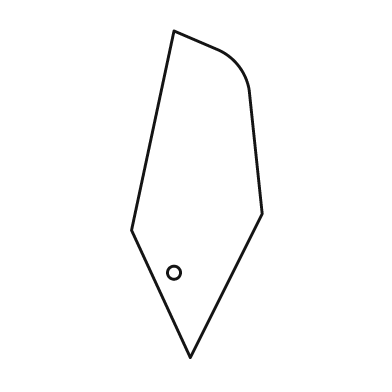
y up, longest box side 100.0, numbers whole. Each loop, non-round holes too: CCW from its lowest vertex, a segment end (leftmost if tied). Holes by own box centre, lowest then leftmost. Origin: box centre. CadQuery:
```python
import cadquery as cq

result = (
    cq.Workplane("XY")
    .moveTo(-2.0, -50.0)
    .lineTo(20.0, -6.0)
    .lineTo(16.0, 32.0)
    .threePointArc((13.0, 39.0), (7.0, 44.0))
    .lineTo(-7.0, 50.0)
    .lineTo(-20.0, -11.0)
    .close()
    .moveTo(-7.0, -24.0)
    .circle(2.0)
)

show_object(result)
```